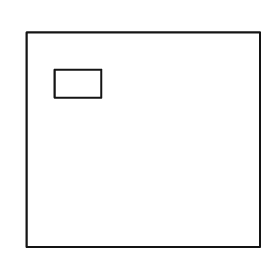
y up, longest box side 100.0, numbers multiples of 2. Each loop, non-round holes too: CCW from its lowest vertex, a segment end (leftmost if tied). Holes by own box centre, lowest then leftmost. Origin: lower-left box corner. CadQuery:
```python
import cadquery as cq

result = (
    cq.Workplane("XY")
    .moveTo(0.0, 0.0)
    .lineTo(100.0, 0.0)
    .lineTo(100.0, 92.0)
    .lineTo(0.0, 92.0)
    .close()
    .moveTo(12.0, 64.0)
    .lineTo(32.0, 64.0)
    .lineTo(32.0, 76.0)
    .lineTo(12.0, 76.0)
    .close()
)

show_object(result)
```